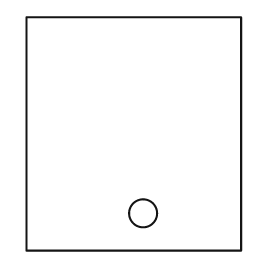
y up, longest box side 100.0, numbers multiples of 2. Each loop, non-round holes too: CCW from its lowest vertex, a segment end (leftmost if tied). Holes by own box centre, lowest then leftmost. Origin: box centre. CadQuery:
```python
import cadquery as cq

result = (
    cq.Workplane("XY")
    .moveTo(-46.0, -50.0)
    .lineTo(46.0, -50.0)
    .lineTo(46.0, 50.0)
    .lineTo(-46.0, 50.0)
    .close()
    .moveTo(4.0, -34.0)
    .circle(6.0)
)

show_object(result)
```